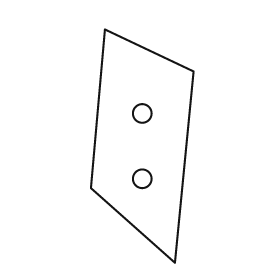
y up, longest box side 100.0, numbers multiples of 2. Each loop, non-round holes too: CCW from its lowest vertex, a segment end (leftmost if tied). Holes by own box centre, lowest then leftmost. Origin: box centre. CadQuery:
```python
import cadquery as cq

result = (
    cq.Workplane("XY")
    .moveTo(14.0, -50.0)
    .lineTo(22.0, 32.0)
    .lineTo(-16.0, 50.0)
    .lineTo(-22.0, -18.0)
    .close()
    .moveTo(0.0, -14.0)
    .circle(4.0)
    .moveTo(0.0, 14.0)
    .circle(4.0)
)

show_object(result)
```